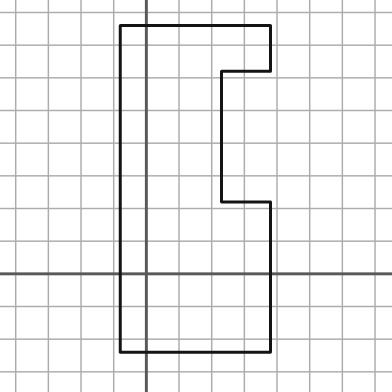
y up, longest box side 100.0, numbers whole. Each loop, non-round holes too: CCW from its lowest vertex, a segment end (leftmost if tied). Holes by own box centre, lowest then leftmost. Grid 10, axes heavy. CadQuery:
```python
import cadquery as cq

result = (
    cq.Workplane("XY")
    .moveTo(-8.0, -24.0)
    .lineTo(38.0, -24.0)
    .lineTo(38.0, 22.0)
    .lineTo(23.0, 22.0)
    .lineTo(23.0, 62.0)
    .lineTo(38.0, 62.0)
    .lineTo(38.0, 76.0)
    .lineTo(-8.0, 76.0)
    .close()
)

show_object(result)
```